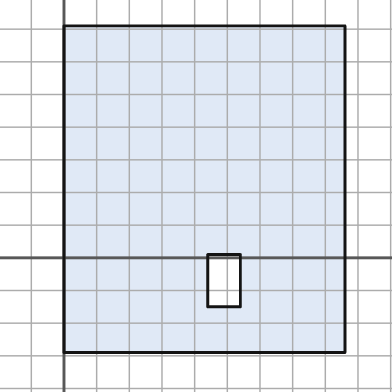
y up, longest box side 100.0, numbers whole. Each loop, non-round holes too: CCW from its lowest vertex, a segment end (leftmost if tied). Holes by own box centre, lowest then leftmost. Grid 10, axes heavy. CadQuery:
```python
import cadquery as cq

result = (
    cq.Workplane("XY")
    .moveTo(0.0, -29.0)
    .lineTo(86.0, -29.0)
    .lineTo(86.0, 71.0)
    .lineTo(0.0, 71.0)
    .close()
    .moveTo(44.0, -15.0)
    .lineTo(54.0, -15.0)
    .lineTo(54.0, 1.0)
    .lineTo(44.0, 1.0)
    .close()
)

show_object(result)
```